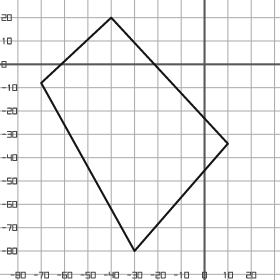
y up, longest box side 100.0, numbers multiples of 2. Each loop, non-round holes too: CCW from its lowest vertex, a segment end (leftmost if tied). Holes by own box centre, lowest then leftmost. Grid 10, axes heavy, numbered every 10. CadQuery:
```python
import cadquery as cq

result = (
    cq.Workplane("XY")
    .moveTo(-30.0, -80.0)
    .lineTo(10.0, -34.0)
    .lineTo(-40.0, 20.0)
    .lineTo(-70.0, -8.0)
    .close()
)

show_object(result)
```